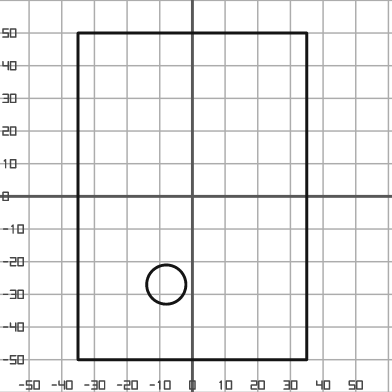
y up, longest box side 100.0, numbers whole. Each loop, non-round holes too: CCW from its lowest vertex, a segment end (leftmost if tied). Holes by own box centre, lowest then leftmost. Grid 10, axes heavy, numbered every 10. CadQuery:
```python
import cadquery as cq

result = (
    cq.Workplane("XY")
    .moveTo(-35.0, -50.0)
    .lineTo(35.0, -50.0)
    .lineTo(35.0, 50.0)
    .lineTo(-35.0, 50.0)
    .close()
    .moveTo(-8.0, -27.0)
    .circle(6.0)
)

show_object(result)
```